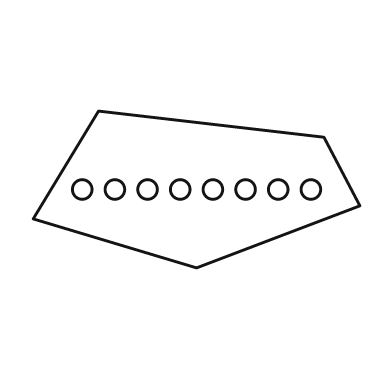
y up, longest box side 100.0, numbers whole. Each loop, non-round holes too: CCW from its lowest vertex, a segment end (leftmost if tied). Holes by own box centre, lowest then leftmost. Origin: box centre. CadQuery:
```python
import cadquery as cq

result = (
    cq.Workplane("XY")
    .moveTo(0.0, -24.0)
    .lineTo(50.0, -5.0)
    .lineTo(39.0, 16.0)
    .lineTo(-30.0, 24.0)
    .lineTo(-50.0, -9.0)
    .close()
    .moveTo(-35.0, 0.0)
    .circle(3.0)
    .moveTo(-25.0, 0.0)
    .circle(3.0)
    .moveTo(-15.0, 0.0)
    .circle(3.0)
    .moveTo(-5.0, 0.0)
    .circle(3.0)
    .moveTo(5.0, 0.0)
    .circle(3.0)
    .moveTo(15.0, 0.0)
    .circle(3.0)
    .moveTo(25.0, 0.0)
    .circle(3.0)
    .moveTo(35.0, 0.0)
    .circle(3.0)
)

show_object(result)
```